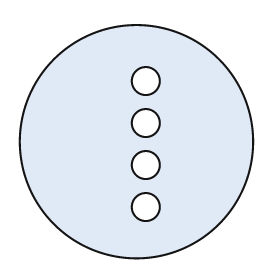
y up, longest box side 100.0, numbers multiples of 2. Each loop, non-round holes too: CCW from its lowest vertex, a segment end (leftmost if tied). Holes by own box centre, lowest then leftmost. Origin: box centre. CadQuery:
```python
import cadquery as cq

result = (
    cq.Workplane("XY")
    .moveTo(0.0, 0.0)
    .circle(50.0)
    .moveTo(4.0, -28.0)
    .circle(6.0)
    .moveTo(4.0, -10.0)
    .circle(6.0)
    .moveTo(4.0, 8.0)
    .circle(6.0)
    .moveTo(4.0, 26.0)
    .circle(6.0)
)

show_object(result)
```